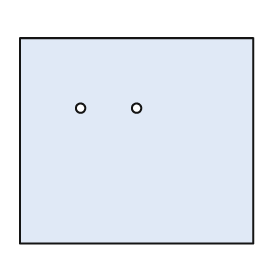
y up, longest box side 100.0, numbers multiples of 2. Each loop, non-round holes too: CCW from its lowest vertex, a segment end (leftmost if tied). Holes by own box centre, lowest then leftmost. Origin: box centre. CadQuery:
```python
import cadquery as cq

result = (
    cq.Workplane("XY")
    .moveTo(-50.0, -44.0)
    .lineTo(50.0, -44.0)
    .lineTo(50.0, 44.0)
    .lineTo(-50.0, 44.0)
    .close()
    .moveTo(-24.0, 14.0)
    .circle(2.0)
    .moveTo(0.0, 14.0)
    .circle(2.0)
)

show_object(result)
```